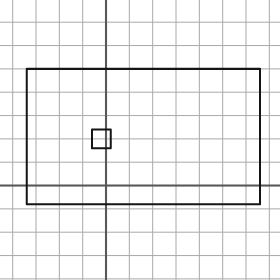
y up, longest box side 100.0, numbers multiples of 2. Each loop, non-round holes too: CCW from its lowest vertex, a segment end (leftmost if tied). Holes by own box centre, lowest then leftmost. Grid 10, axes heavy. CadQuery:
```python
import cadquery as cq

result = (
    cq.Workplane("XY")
    .moveTo(-34.0, -8.0)
    .lineTo(66.0, -8.0)
    .lineTo(66.0, 50.0)
    .lineTo(-34.0, 50.0)
    .close()
    .moveTo(-6.0, 16.0)
    .lineTo(2.0, 16.0)
    .lineTo(2.0, 24.0)
    .lineTo(-6.0, 24.0)
    .close()
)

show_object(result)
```